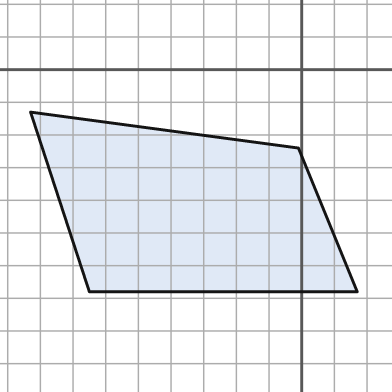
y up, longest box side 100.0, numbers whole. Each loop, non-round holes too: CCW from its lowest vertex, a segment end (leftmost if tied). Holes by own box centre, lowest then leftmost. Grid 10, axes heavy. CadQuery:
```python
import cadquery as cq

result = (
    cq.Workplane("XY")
    .moveTo(-65.0, -68.0)
    .lineTo(17.0, -68.0)
    .lineTo(-1.0, -24.0)
    .lineTo(-83.0, -13.0)
    .close()
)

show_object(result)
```